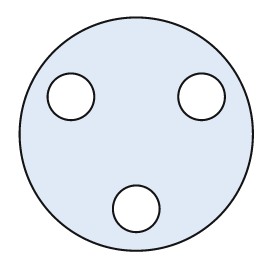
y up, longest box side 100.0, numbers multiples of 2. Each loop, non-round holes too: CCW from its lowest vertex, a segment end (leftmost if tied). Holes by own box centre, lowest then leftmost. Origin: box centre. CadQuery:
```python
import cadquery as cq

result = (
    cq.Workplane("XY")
    .moveTo(0.0, 0.0)
    .circle(50.0)
    .moveTo(0.0, -32.0)
    .circle(10.0)
    .moveTo(-28.0, 16.0)
    .circle(10.0)
    .moveTo(28.0, 16.0)
    .circle(10.0)
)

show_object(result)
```